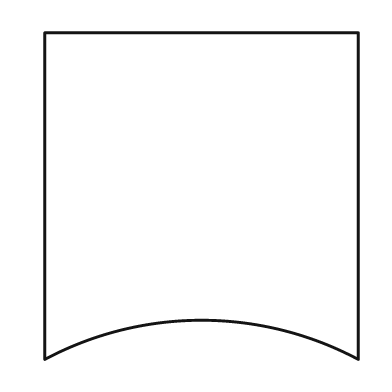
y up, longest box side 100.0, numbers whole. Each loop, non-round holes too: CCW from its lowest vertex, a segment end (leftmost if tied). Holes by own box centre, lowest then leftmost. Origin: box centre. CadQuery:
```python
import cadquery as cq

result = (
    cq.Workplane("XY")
    .moveTo(-48.0, -50.0)
    .threePointArc((0.0, -38.0), (48.0, -50.0))
    .lineTo(48.0, 50.0)
    .lineTo(-48.0, 50.0)
    .close()
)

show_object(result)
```